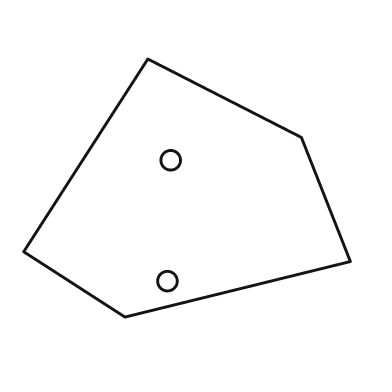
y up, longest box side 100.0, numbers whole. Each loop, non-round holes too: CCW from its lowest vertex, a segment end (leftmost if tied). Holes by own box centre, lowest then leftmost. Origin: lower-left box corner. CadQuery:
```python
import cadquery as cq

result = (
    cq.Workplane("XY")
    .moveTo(31.0, 0.0)
    .lineTo(100.0, 17.0)
    .lineTo(85.0, 55.0)
    .lineTo(38.0, 79.0)
    .lineTo(0.0, 20.0)
    .close()
    .moveTo(44.0, 11.0)
    .circle(3.0)
    .moveTo(45.0, 48.0)
    .circle(3.0)
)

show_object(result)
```